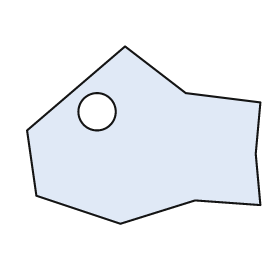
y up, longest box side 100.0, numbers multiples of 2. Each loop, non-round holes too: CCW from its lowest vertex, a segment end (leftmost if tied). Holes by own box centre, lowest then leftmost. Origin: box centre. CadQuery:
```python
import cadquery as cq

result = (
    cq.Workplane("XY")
    .moveTo(-10.0, -38.0)
    .lineTo(22.0, -28.0)
    .lineTo(50.0, -30.0)
    .lineTo(48.0, -8.0)
    .lineTo(50.0, 14.0)
    .lineTo(18.0, 18.0)
    .lineTo(-8.0, 38.0)
    .lineTo(-50.0, 2.0)
    .lineTo(-46.0, -26.0)
    .close()
    .moveTo(-20.0, 10.0)
    .circle(8.0)
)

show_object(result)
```